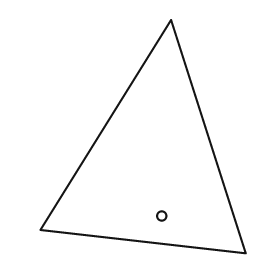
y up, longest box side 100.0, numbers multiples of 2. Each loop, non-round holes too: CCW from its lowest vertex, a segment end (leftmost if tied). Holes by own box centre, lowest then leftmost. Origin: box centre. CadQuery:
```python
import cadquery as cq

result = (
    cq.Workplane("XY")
    .moveTo(44.0, -50.0)
    .lineTo(12.0, 50.0)
    .lineTo(-44.0, -40.0)
    .close()
    .moveTo(8.0, -34.0)
    .circle(2.0)
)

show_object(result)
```